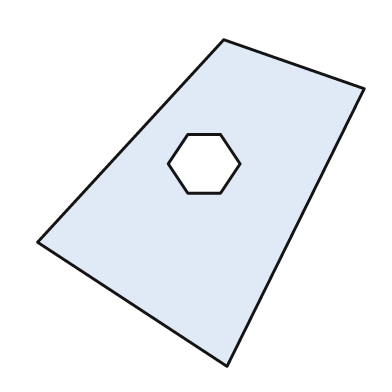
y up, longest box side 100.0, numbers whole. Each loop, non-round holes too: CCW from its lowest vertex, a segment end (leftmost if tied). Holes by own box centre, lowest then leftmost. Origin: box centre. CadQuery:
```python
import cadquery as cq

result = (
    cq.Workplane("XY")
    .moveTo(8.0, -50.0)
    .lineTo(50.0, 35.0)
    .lineTo(7.0, 50.0)
    .lineTo(-50.0, -12.0)
    .close()
    .moveTo(-4.0, 3.0)
    .lineTo(6.0, 3.0)
    .lineTo(12.0, 12.0)
    .lineTo(6.0, 21.0)
    .lineTo(-4.0, 21.0)
    .lineTo(-10.0, 12.0)
    .close()
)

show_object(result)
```